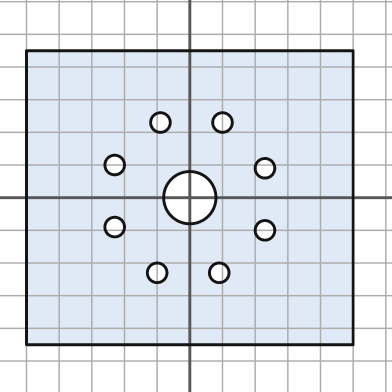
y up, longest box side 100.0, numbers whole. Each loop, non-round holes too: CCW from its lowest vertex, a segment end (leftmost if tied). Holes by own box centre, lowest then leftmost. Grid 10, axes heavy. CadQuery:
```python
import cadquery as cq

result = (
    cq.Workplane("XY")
    .moveTo(-50.0, -45.0)
    .lineTo(50.0, -45.0)
    .lineTo(50.0, 45.0)
    .lineTo(-50.0, 45.0)
    .close()
    .moveTo(-10.0, -23.0)
    .circle(3.0)
    .moveTo(9.0, -23.0)
    .circle(3.0)
    .moveTo(23.0, -10.0)
    .circle(3.0)
    .moveTo(-23.0, -9.0)
    .circle(3.0)
    .moveTo(0.0, 0.0)
    .circle(8.0)
    .moveTo(23.0, 9.0)
    .circle(3.0)
    .moveTo(-23.0, 10.0)
    .circle(3.0)
    .moveTo(-9.0, 23.0)
    .circle(3.0)
    .moveTo(10.0, 23.0)
    .circle(3.0)
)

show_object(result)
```